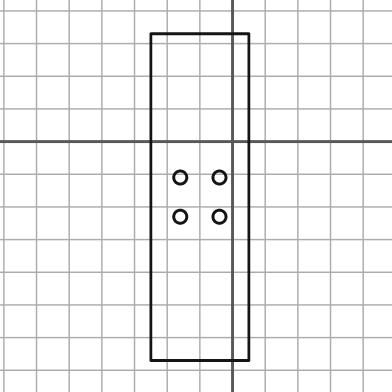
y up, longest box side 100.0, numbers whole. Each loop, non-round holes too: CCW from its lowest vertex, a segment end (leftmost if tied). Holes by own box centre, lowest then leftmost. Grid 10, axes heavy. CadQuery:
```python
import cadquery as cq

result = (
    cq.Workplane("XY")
    .moveTo(-25.0, -67.0)
    .lineTo(5.0, -67.0)
    .lineTo(5.0, 33.0)
    .lineTo(-25.0, 33.0)
    .close()
    .moveTo(-16.0, -23.0)
    .circle(2.0)
    .moveTo(-4.0, -23.0)
    .circle(2.0)
    .moveTo(-16.0, -11.0)
    .circle(2.0)
    .moveTo(-4.0, -11.0)
    .circle(2.0)
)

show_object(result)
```